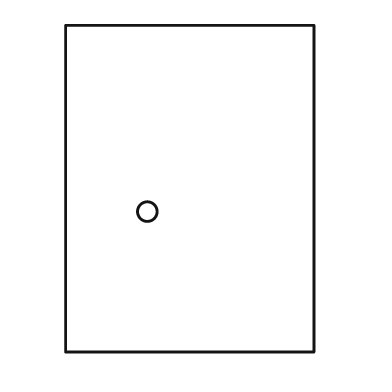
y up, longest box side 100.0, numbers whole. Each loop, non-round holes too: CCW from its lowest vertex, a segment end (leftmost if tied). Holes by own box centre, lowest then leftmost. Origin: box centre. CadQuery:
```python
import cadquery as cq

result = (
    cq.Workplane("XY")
    .moveTo(-38.0, -50.0)
    .lineTo(38.0, -50.0)
    .lineTo(38.0, 50.0)
    .lineTo(-38.0, 50.0)
    .close()
    .moveTo(-13.0, -7.0)
    .circle(3.0)
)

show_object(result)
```